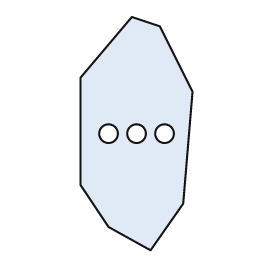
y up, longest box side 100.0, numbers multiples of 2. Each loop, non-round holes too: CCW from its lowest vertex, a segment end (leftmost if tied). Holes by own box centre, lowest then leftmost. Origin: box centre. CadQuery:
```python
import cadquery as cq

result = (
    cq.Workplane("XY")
    .moveTo(6.0, -50.0)
    .lineTo(20.0, -30.0)
    .lineTo(24.0, 18.0)
    .lineTo(10.0, 46.0)
    .lineTo(-2.0, 50.0)
    .lineTo(-24.0, 24.0)
    .lineTo(-24.0, -22.0)
    .lineTo(-12.0, -40.0)
    .close()
    .moveTo(-12.0, 0.0)
    .circle(4.0)
    .moveTo(0.0, 0.0)
    .circle(4.0)
    .moveTo(12.0, 0.0)
    .circle(4.0)
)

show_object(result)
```